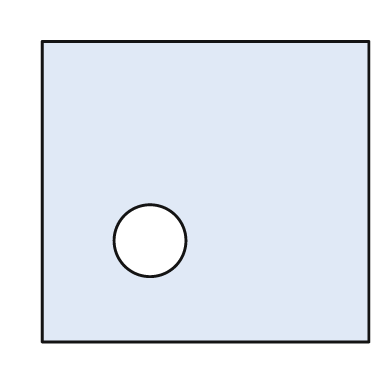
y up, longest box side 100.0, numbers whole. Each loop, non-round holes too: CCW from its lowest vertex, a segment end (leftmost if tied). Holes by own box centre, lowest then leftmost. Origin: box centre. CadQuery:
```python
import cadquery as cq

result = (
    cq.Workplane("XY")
    .moveTo(-50.0, -46.0)
    .lineTo(50.0, -46.0)
    .lineTo(50.0, 46.0)
    .lineTo(-50.0, 46.0)
    .close()
    .moveTo(-17.0, -15.0)
    .circle(11.0)
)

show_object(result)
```